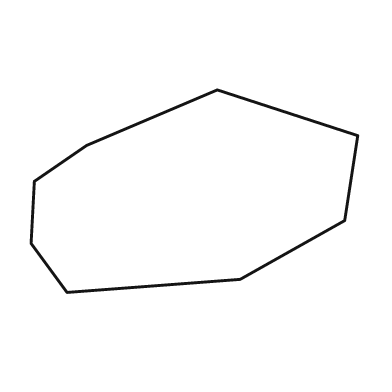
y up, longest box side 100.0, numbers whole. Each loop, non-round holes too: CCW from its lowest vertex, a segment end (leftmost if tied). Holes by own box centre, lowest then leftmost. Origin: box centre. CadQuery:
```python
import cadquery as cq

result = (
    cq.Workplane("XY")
    .moveTo(-39.0, -31.0)
    .lineTo(14.0, -27.0)
    .lineTo(46.0, -9.0)
    .lineTo(50.0, 17.0)
    .lineTo(7.0, 31.0)
    .lineTo(-33.0, 14.0)
    .lineTo(-49.0, 3.0)
    .lineTo(-50.0, -16.0)
    .close()
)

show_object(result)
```